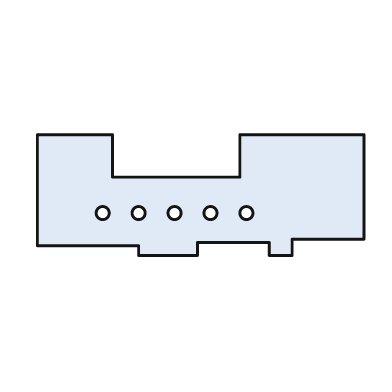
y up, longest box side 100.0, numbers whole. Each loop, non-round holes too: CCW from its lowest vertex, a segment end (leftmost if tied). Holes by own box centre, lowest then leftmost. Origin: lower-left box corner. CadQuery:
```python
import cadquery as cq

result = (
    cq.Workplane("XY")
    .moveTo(31.0, 0.0)
    .lineTo(49.0, 0.0)
    .lineTo(49.0, 4.0)
    .lineTo(71.0, 4.0)
    .lineTo(71.0, 0.0)
    .lineTo(78.0, 0.0)
    .lineTo(78.0, 5.0)
    .lineTo(100.0, 5.0)
    .lineTo(100.0, 37.0)
    .lineTo(62.0, 37.0)
    .lineTo(62.0, 24.0)
    .lineTo(23.0, 24.0)
    .lineTo(23.0, 37.0)
    .lineTo(0.0, 37.0)
    .lineTo(0.0, 3.0)
    .lineTo(31.0, 3.0)
    .close()
    .moveTo(20.0, 13.0)
    .circle(2.0)
    .moveTo(31.0, 13.0)
    .circle(2.0)
    .moveTo(42.0, 13.0)
    .circle(2.0)
    .moveTo(53.0, 13.0)
    .circle(2.0)
    .moveTo(64.0, 13.0)
    .circle(2.0)
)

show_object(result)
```